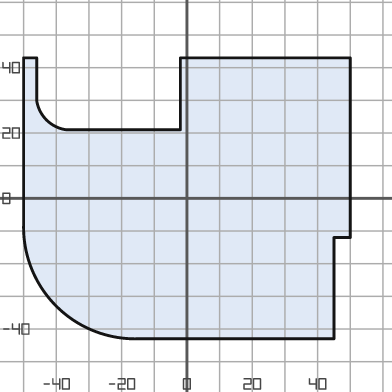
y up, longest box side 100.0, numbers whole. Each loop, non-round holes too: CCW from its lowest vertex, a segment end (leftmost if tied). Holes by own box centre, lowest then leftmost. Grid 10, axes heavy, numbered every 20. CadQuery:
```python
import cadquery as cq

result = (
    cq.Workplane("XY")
    .moveTo(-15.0, -43.0)
    .lineTo(45.0, -43.0)
    .lineTo(45.0, -12.0)
    .lineTo(50.0, -12.0)
    .lineTo(50.0, 43.0)
    .lineTo(-2.0, 43.0)
    .lineTo(-2.0, 21.0)
    .lineTo(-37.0, 21.0)
    .threePointArc((-43.0, 24.0), (-46.0, 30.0))
    .lineTo(-46.0, 43.0)
    .lineTo(-50.0, 43.0)
    .lineTo(-50.0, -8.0)
    .threePointArc((-40.0, -33.0), (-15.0, -43.0))
    .close()
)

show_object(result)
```